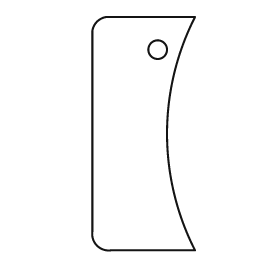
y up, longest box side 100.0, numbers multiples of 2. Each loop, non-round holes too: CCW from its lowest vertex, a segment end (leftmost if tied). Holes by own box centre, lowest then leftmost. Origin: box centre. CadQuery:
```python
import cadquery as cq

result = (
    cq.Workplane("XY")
    .moveTo(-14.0, -50.0)
    .lineTo(22.0, -50.0)
    .threePointArc((10.0, 0.0), (22.0, 50.0))
    .lineTo(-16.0, 50.0)
    .threePointArc((-20.0, 48.0), (-22.0, 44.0))
    .lineTo(-22.0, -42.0)
    .threePointArc((-20.0, -48.0), (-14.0, -50.0))
    .close()
    .moveTo(6.0, 36.0)
    .circle(4.0)
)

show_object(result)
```